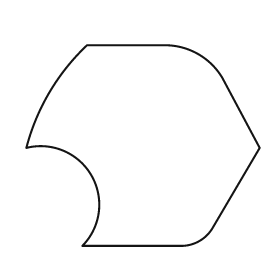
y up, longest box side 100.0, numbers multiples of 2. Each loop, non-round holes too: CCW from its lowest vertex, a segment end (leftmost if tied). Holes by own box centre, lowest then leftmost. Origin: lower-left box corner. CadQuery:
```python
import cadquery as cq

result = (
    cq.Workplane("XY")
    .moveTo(24.0, 0.0)
    .lineTo(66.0, 0.0)
    .threePointArc((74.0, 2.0), (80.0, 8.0))
    .lineTo(100.0, 42.0)
    .lineTo(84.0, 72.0)
    .threePointArc((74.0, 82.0), (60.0, 86.0))
    .lineTo(26.0, 86.0)
    .threePointArc((10.0, 66.0), (0.0, 42.0))
    .threePointArc((28.0, 30.0), (24.0, 0.0))
    .close()
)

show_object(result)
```